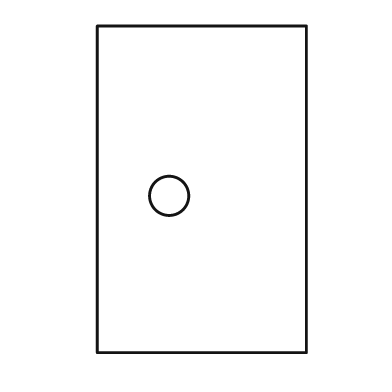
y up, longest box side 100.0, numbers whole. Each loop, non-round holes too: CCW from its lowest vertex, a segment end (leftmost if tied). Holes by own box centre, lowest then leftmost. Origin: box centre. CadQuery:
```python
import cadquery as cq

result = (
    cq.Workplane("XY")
    .moveTo(-32.0, -50.0)
    .lineTo(32.0, -50.0)
    .lineTo(32.0, 50.0)
    .lineTo(-32.0, 50.0)
    .close()
    .moveTo(-10.0, -2.0)
    .circle(6.0)
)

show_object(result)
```